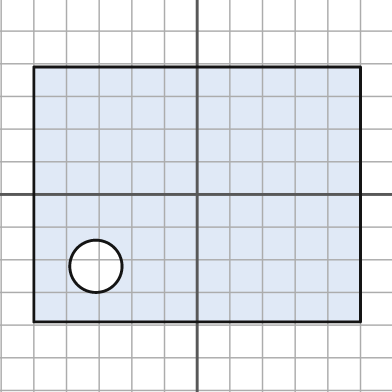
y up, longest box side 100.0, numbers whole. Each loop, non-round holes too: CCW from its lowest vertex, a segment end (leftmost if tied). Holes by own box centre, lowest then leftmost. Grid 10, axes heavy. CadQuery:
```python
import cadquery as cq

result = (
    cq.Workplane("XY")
    .moveTo(-50.0, -39.0)
    .lineTo(50.0, -39.0)
    .lineTo(50.0, 39.0)
    .lineTo(-50.0, 39.0)
    .close()
    .moveTo(-31.0, -22.0)
    .circle(8.0)
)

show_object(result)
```